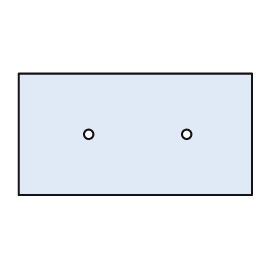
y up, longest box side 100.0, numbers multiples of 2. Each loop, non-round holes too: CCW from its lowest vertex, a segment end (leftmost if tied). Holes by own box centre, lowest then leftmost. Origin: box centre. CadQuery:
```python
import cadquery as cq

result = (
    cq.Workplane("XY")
    .moveTo(-50.0, -26.0)
    .lineTo(50.0, -26.0)
    .lineTo(50.0, 26.0)
    .lineTo(-50.0, 26.0)
    .close()
    .moveTo(-20.0, 0.0)
    .circle(2.0)
    .moveTo(22.0, 0.0)
    .circle(2.0)
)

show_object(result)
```